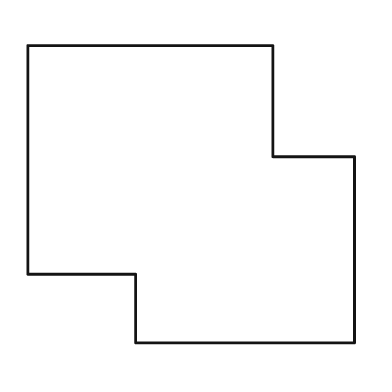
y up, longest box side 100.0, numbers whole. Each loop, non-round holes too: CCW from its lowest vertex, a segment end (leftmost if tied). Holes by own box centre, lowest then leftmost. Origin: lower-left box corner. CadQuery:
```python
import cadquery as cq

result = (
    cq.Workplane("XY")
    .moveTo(33.0, 0.0)
    .lineTo(100.0, 0.0)
    .lineTo(100.0, 57.0)
    .lineTo(75.0, 57.0)
    .lineTo(75.0, 91.0)
    .lineTo(0.0, 91.0)
    .lineTo(0.0, 21.0)
    .lineTo(33.0, 21.0)
    .close()
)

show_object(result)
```